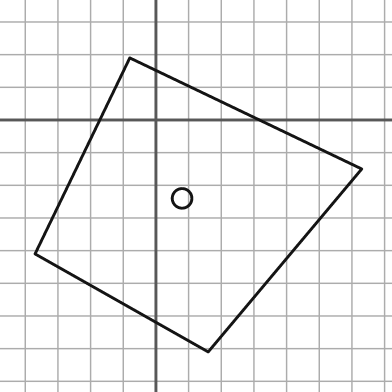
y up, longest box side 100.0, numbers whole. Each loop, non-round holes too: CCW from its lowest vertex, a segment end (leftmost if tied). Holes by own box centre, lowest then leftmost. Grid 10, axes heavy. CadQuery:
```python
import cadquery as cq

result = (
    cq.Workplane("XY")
    .moveTo(16.0, -71.0)
    .lineTo(63.0, -15.0)
    .lineTo(-8.0, 19.0)
    .lineTo(-37.0, -41.0)
    .close()
    .moveTo(8.0, -24.0)
    .circle(3.0)
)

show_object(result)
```